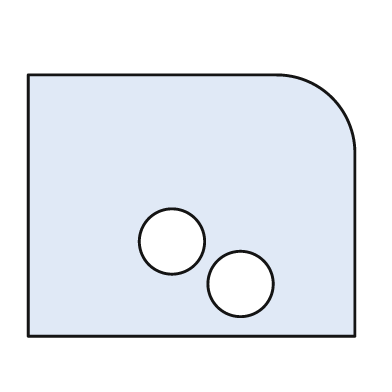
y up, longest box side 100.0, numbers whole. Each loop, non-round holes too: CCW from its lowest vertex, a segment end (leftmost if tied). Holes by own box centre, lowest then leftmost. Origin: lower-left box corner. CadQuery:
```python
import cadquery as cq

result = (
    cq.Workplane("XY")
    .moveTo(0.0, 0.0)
    .lineTo(100.0, 0.0)
    .lineTo(100.0, 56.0)
    .threePointArc((93.0, 73.0), (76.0, 80.0))
    .lineTo(0.0, 80.0)
    .close()
    .moveTo(65.0, 16.0)
    .circle(10.0)
    .moveTo(44.0, 29.0)
    .circle(10.0)
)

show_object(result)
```